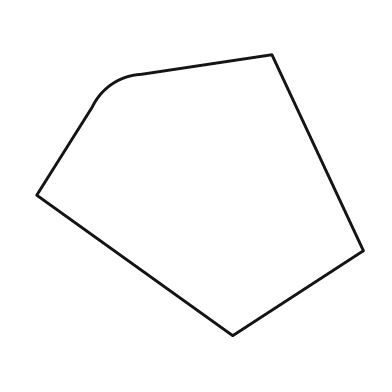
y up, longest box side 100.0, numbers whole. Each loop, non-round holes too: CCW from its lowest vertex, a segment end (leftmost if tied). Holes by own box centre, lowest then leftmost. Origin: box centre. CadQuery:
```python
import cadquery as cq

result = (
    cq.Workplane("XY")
    .moveTo(10.0, -43.0)
    .lineTo(50.0, -17.0)
    .lineTo(22.0, 43.0)
    .lineTo(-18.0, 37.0)
    .threePointArc((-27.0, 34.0), (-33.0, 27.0))
    .lineTo(-50.0, 0.0)
    .close()
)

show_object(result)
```